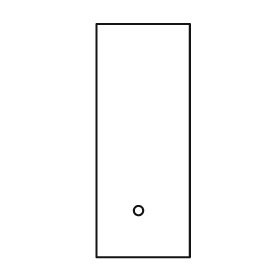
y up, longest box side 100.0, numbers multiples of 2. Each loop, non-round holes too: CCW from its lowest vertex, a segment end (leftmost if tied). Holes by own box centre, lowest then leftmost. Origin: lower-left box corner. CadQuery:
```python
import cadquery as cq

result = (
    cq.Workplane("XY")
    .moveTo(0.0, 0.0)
    .lineTo(40.0, 0.0)
    .lineTo(40.0, 100.0)
    .lineTo(0.0, 100.0)
    .close()
    .moveTo(18.0, 20.0)
    .circle(2.0)
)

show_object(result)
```